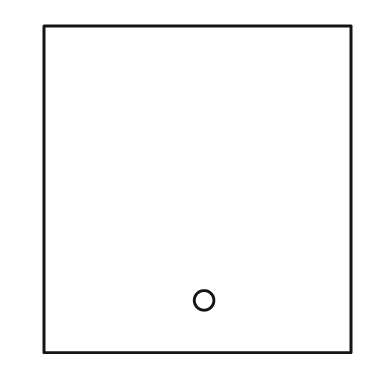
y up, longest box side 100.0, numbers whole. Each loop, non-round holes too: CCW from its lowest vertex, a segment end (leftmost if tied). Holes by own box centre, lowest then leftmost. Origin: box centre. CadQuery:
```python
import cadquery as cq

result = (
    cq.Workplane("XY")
    .moveTo(-47.0, -50.0)
    .lineTo(47.0, -50.0)
    .lineTo(47.0, 50.0)
    .lineTo(-47.0, 50.0)
    .close()
    .moveTo(2.0, -34.0)
    .circle(3.0)
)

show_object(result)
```